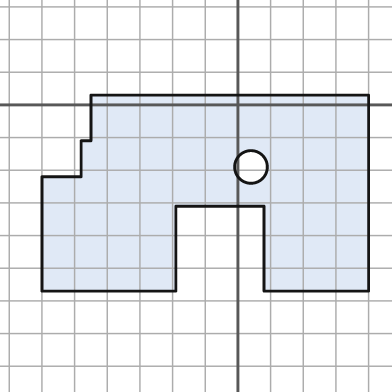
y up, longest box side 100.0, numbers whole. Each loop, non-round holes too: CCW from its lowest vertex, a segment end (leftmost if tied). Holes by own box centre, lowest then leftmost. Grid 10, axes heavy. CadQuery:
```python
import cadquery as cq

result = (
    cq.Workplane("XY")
    .moveTo(-60.0, -57.0)
    .lineTo(-19.0, -57.0)
    .lineTo(-19.0, -31.0)
    .lineTo(8.0, -31.0)
    .lineTo(8.0, -57.0)
    .lineTo(40.0, -57.0)
    .lineTo(40.0, 3.0)
    .lineTo(-45.0, 3.0)
    .lineTo(-45.0, -11.0)
    .lineTo(-48.0, -11.0)
    .lineTo(-48.0, -22.0)
    .lineTo(-60.0, -22.0)
    .close()
    .moveTo(4.0, -19.0)
    .circle(5.0)
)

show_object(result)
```